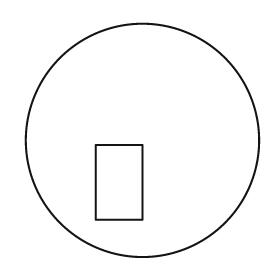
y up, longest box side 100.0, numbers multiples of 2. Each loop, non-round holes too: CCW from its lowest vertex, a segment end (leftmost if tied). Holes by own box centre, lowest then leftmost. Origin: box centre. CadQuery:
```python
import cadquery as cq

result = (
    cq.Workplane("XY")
    .moveTo(0.0, 0.0)
    .circle(50.0)
    .moveTo(-20.0, -34.0)
    .lineTo(0.0, -34.0)
    .lineTo(0.0, -2.0)
    .lineTo(-20.0, -2.0)
    .close()
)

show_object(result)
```